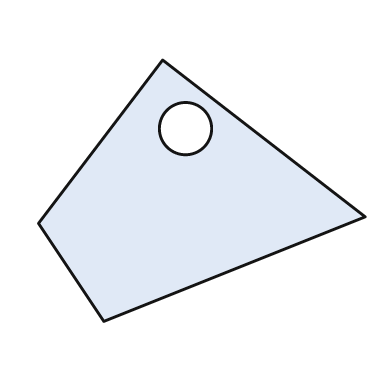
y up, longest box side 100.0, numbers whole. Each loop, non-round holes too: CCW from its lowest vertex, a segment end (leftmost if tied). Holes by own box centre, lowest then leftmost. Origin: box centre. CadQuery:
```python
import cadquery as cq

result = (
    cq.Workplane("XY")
    .moveTo(-30.0, -40.0)
    .lineTo(50.0, -8.0)
    .lineTo(-12.0, 40.0)
    .lineTo(-50.0, -10.0)
    .close()
    .moveTo(-5.0, 19.0)
    .circle(8.0)
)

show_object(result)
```